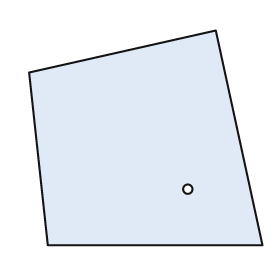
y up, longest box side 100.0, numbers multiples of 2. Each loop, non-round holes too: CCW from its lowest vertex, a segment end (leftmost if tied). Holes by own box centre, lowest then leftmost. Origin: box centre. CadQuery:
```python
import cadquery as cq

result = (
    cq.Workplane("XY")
    .moveTo(-42.0, -46.0)
    .lineTo(50.0, -46.0)
    .lineTo(30.0, 46.0)
    .lineTo(-50.0, 28.0)
    .close()
    .moveTo(18.0, -22.0)
    .circle(2.0)
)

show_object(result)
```